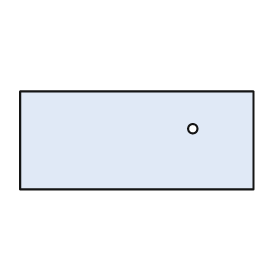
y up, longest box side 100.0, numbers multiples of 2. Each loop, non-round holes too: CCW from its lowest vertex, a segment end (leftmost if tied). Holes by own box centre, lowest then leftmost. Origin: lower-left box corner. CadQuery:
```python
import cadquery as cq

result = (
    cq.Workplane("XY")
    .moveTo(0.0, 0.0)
    .lineTo(100.0, 0.0)
    .lineTo(100.0, 42.0)
    .lineTo(0.0, 42.0)
    .close()
    .moveTo(74.0, 26.0)
    .circle(2.0)
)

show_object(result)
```